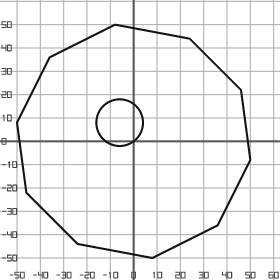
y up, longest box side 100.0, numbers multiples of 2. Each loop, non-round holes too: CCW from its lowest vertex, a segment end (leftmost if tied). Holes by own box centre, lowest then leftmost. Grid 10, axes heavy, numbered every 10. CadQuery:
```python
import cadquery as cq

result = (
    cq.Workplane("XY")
    .moveTo(8.0, -50.0)
    .lineTo(36.0, -36.0)
    .lineTo(50.0, -8.0)
    .lineTo(46.0, 22.0)
    .lineTo(24.0, 44.0)
    .lineTo(-8.0, 50.0)
    .lineTo(-36.0, 36.0)
    .lineTo(-50.0, 8.0)
    .lineTo(-46.0, -22.0)
    .lineTo(-24.0, -44.0)
    .close()
    .moveTo(-6.0, 8.0)
    .circle(10.0)
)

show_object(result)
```